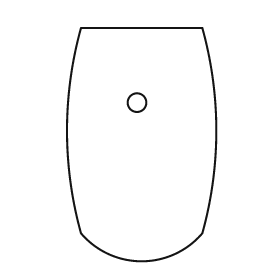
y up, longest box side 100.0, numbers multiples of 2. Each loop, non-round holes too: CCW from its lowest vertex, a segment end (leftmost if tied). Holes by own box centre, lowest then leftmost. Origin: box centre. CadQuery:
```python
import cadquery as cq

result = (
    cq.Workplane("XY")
    .moveTo(-26.0, -38.0)
    .threePointArc((0.0, -50.0), (26.0, -38.0))
    .threePointArc((32.0, 6.0), (26.0, 50.0))
    .lineTo(-26.0, 50.0)
    .threePointArc((-32.0, 6.0), (-26.0, -38.0))
    .close()
    .moveTo(-2.0, 18.0)
    .circle(4.0)
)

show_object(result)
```